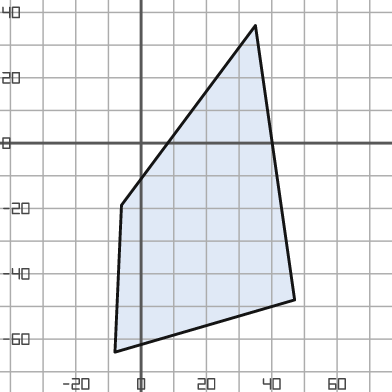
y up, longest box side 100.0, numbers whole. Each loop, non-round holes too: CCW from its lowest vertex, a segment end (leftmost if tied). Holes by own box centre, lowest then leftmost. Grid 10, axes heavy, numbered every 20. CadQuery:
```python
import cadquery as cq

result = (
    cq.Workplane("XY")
    .moveTo(-8.0, -64.0)
    .lineTo(47.0, -48.0)
    .lineTo(35.0, 36.0)
    .lineTo(-6.0, -19.0)
    .close()
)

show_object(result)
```